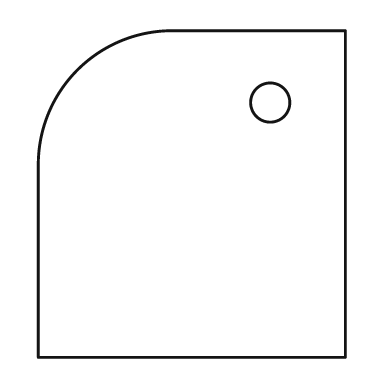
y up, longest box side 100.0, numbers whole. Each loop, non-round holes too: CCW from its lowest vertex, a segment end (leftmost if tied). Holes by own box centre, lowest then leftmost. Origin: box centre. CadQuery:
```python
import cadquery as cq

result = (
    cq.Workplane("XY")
    .moveTo(-47.0, -50.0)
    .lineTo(47.0, -50.0)
    .lineTo(47.0, 50.0)
    .lineTo(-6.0, 50.0)
    .threePointArc((-35.0, 38.0), (-47.0, 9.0))
    .close()
    .moveTo(24.0, 28.0)
    .circle(6.0)
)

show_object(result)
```